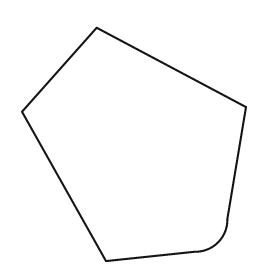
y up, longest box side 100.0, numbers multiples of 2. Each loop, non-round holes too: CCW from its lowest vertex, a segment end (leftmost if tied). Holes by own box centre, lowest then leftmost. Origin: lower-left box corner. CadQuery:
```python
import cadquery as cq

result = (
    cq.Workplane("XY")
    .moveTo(36.0, 0.0)
    .lineTo(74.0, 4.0)
    .threePointArc((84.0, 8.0), (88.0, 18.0))
    .lineTo(96.0, 66.0)
    .lineTo(32.0, 100.0)
    .lineTo(0.0, 64.0)
    .close()
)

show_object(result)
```